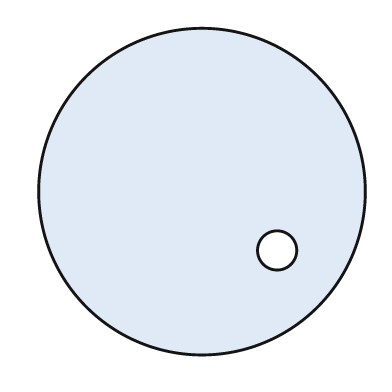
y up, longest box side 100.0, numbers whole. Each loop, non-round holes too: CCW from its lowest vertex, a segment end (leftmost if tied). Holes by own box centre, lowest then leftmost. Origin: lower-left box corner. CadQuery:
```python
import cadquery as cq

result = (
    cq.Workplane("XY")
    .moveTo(50.0, 50.0)
    .circle(50.0)
    .moveTo(73.0, 32.0)
    .circle(6.0)
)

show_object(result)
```